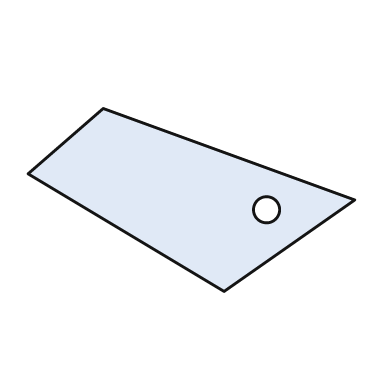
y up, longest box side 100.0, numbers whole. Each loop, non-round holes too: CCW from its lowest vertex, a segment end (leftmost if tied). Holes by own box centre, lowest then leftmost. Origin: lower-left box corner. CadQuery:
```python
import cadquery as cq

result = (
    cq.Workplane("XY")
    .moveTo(60.0, 0.0)
    .lineTo(100.0, 28.0)
    .lineTo(23.0, 56.0)
    .lineTo(0.0, 36.0)
    .close()
    .moveTo(73.0, 25.0)
    .circle(4.0)
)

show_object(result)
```